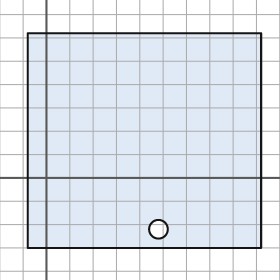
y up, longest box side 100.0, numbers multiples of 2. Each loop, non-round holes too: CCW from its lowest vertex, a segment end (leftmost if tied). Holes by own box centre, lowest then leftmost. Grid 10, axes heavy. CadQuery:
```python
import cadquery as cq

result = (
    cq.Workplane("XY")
    .moveTo(-8.0, -30.0)
    .lineTo(92.0, -30.0)
    .lineTo(92.0, 62.0)
    .lineTo(-8.0, 62.0)
    .close()
    .moveTo(48.0, -22.0)
    .circle(4.0)
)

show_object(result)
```